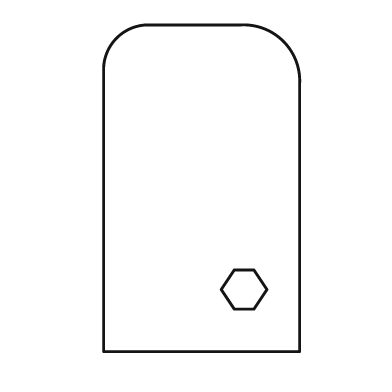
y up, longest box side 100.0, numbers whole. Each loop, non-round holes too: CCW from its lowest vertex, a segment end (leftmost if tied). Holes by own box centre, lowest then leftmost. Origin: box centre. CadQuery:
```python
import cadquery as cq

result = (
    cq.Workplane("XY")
    .moveTo(-30.0, -50.0)
    .lineTo(30.0, -50.0)
    .lineTo(30.0, 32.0)
    .threePointArc((25.0, 45.0), (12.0, 50.0))
    .lineTo(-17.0, 50.0)
    .threePointArc((-26.0, 46.0), (-30.0, 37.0))
    .close()
    .moveTo(10.0, -37.0)
    .lineTo(16.0, -37.0)
    .lineTo(20.0, -31.0)
    .lineTo(16.0, -25.0)
    .lineTo(10.0, -25.0)
    .lineTo(6.0, -31.0)
    .close()
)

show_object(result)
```